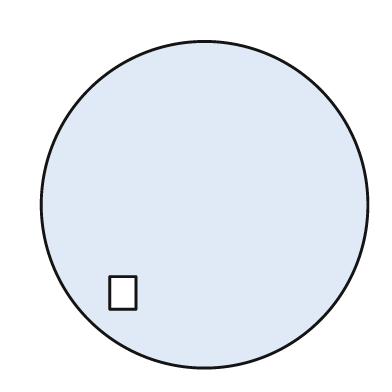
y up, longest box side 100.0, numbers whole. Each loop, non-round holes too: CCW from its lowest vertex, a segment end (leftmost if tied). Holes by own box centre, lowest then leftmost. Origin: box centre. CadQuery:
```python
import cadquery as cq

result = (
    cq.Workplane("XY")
    .moveTo(0.0, 0.0)
    .circle(50.0)
    .moveTo(-29.0, -32.0)
    .lineTo(-21.0, -32.0)
    .lineTo(-21.0, -22.0)
    .lineTo(-29.0, -22.0)
    .close()
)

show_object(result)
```